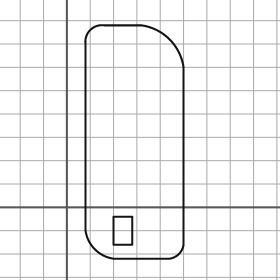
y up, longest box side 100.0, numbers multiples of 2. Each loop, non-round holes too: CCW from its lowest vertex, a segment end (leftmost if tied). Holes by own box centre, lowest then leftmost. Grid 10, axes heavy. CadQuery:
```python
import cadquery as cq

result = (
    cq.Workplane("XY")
    .moveTo(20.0, -22.0)
    .lineTo(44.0, -22.0)
    .threePointArc((48.0, -20.0), (50.0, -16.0))
    .lineTo(50.0, 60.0)
    .threePointArc((44.0, 72.0), (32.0, 78.0))
    .lineTo(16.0, 78.0)
    .threePointArc((10.0, 76.0), (8.0, 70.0))
    .lineTo(8.0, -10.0)
    .threePointArc((12.0, -18.0), (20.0, -22.0))
    .close()
    .moveTo(20.0, -16.0)
    .lineTo(28.0, -16.0)
    .lineTo(28.0, -4.0)
    .lineTo(20.0, -4.0)
    .close()
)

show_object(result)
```